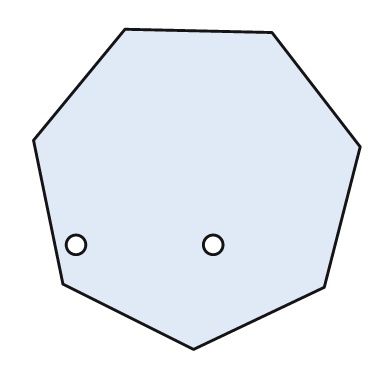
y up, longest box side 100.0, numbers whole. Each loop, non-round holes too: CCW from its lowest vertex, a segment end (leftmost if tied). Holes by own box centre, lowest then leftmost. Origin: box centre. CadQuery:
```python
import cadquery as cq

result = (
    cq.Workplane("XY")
    .moveTo(-1.0, -49.0)
    .lineTo(39.0, -30.0)
    .lineTo(50.0, 13.0)
    .lineTo(23.0, 48.0)
    .lineTo(-22.0, 49.0)
    .lineTo(-50.0, 15.0)
    .lineTo(-41.0, -29.0)
    .close()
    .moveTo(-37.0, -17.0)
    .circle(3.0)
    .moveTo(5.0, -17.0)
    .circle(3.0)
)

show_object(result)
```